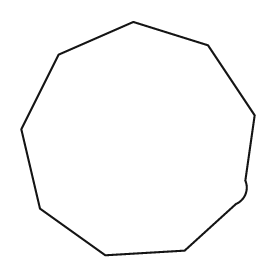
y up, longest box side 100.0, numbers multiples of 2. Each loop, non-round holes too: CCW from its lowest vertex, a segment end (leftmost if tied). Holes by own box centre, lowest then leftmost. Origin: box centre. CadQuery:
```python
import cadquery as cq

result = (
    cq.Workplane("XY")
    .moveTo(-14.0, -50.0)
    .lineTo(20.0, -48.0)
    .lineTo(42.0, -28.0)
    .threePointArc((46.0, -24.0), (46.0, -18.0))
    .lineTo(50.0, 10.0)
    .lineTo(30.0, 40.0)
    .lineTo(-2.0, 50.0)
    .lineTo(-34.0, 36.0)
    .lineTo(-50.0, 4.0)
    .lineTo(-42.0, -30.0)
    .close()
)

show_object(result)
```